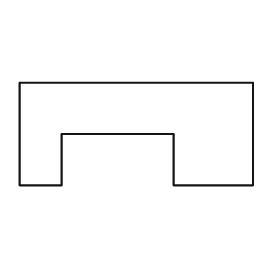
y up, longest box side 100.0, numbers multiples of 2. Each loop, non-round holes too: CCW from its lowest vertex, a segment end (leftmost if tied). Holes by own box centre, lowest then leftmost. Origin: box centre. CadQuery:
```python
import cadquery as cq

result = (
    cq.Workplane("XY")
    .moveTo(-50.0, -22.0)
    .lineTo(-32.0, -22.0)
    .lineTo(-32.0, 0.0)
    .lineTo(16.0, 0.0)
    .lineTo(16.0, -22.0)
    .lineTo(50.0, -22.0)
    .lineTo(50.0, 22.0)
    .lineTo(-50.0, 22.0)
    .close()
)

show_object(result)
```